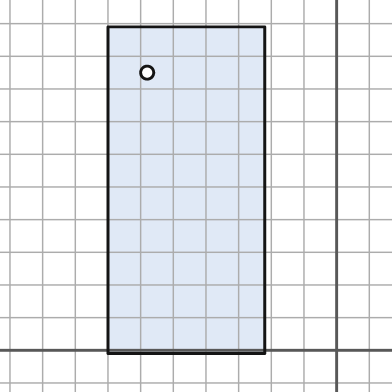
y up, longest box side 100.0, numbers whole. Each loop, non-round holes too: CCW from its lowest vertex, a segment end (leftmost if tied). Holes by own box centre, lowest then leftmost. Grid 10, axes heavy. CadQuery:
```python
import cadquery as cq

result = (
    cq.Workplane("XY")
    .moveTo(-70.0, -1.0)
    .lineTo(-22.0, -1.0)
    .lineTo(-22.0, 99.0)
    .lineTo(-70.0, 99.0)
    .close()
    .moveTo(-58.0, 85.0)
    .circle(2.0)
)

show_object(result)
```